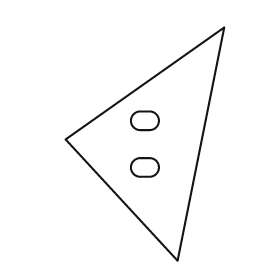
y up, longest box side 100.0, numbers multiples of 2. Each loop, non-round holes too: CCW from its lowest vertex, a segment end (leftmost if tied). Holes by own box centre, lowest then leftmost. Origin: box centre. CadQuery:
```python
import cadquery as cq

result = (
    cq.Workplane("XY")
    .moveTo(14.0, -50.0)
    .lineTo(34.0, 50.0)
    .lineTo(-34.0, 2.0)
    .close()
    .moveTo(-2.0, -14.0)
    .lineTo(2.0, -14.0)
    .threePointArc((6.0, -10.0), (2.0, -6.0))
    .lineTo(-2.0, -6.0)
    .threePointArc((-6.0, -10.0), (-2.0, -14.0))
    .close()
    .moveTo(-2.0, 6.0)
    .lineTo(2.0, 6.0)
    .threePointArc((6.0, 10.0), (2.0, 14.0))
    .lineTo(-2.0, 14.0)
    .threePointArc((-6.0, 10.0), (-2.0, 6.0))
    .close()
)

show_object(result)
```